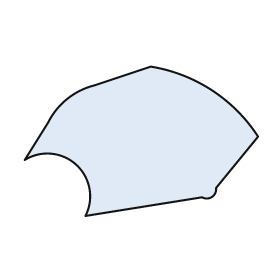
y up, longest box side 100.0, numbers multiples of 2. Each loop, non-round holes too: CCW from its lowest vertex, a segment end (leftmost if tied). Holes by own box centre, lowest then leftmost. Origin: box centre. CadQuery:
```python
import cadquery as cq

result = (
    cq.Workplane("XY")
    .moveTo(-24.0, -32.0)
    .lineTo(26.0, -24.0)
    .threePointArc((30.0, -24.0), (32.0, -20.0))
    .lineTo(50.0, 2.0)
    .threePointArc((30.0, 22.0), (4.0, 32.0))
    .lineTo(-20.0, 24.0)
    .threePointArc((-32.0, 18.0), (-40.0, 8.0))
    .lineTo(-50.0, -8.0)
    .threePointArc((-28.0, -10.0), (-24.0, -32.0))
    .close()
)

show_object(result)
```